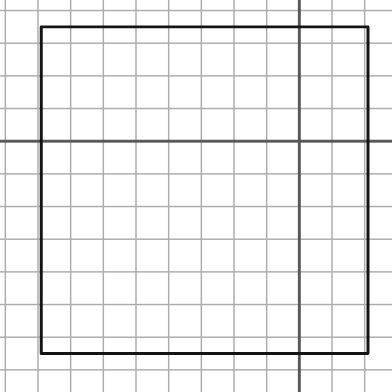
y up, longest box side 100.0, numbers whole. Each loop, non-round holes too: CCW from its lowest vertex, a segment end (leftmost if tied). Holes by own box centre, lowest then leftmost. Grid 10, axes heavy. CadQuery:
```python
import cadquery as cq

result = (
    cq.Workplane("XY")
    .moveTo(-79.0, -65.0)
    .lineTo(21.0, -65.0)
    .lineTo(21.0, 35.0)
    .lineTo(-79.0, 35.0)
    .close()
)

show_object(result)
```